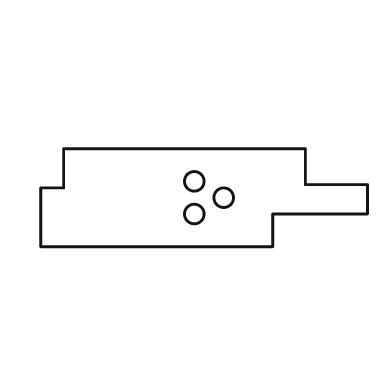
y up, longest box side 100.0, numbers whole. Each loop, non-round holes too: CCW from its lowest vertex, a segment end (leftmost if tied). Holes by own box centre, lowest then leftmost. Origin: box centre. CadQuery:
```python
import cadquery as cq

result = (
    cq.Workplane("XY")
    .moveTo(-50.0, -15.0)
    .lineTo(21.0, -15.0)
    .lineTo(21.0, -5.0)
    .lineTo(50.0, -5.0)
    .lineTo(50.0, 4.0)
    .lineTo(31.0, 4.0)
    .lineTo(31.0, 15.0)
    .lineTo(-43.0, 15.0)
    .lineTo(-43.0, 3.0)
    .lineTo(-50.0, 3.0)
    .close()
    .moveTo(-3.0, -5.0)
    .circle(3.0)
    .moveTo(6.0, 0.0)
    .circle(3.0)
    .moveTo(-3.0, 5.0)
    .circle(3.0)
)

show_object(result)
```